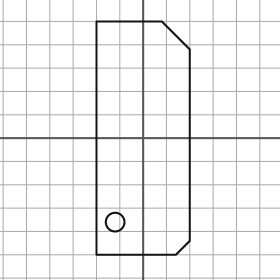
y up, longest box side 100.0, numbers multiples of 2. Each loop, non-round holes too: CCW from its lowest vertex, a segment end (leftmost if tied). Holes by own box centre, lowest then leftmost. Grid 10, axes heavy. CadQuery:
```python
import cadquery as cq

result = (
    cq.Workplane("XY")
    .moveTo(-20.0, -50.0)
    .lineTo(14.0, -50.0)
    .lineTo(20.0, -44.0)
    .lineTo(20.0, 38.0)
    .lineTo(8.0, 50.0)
    .lineTo(-20.0, 50.0)
    .close()
    .moveTo(-12.0, -36.0)
    .circle(4.0)
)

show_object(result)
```